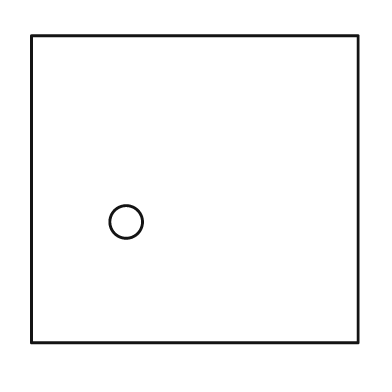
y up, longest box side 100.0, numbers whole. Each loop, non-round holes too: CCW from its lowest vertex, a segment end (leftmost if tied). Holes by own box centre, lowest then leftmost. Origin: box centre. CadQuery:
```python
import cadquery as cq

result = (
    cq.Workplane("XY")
    .moveTo(-50.0, -47.0)
    .lineTo(50.0, -47.0)
    .lineTo(50.0, 47.0)
    .lineTo(-50.0, 47.0)
    .close()
    .moveTo(-21.0, -10.0)
    .circle(5.0)
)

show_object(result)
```